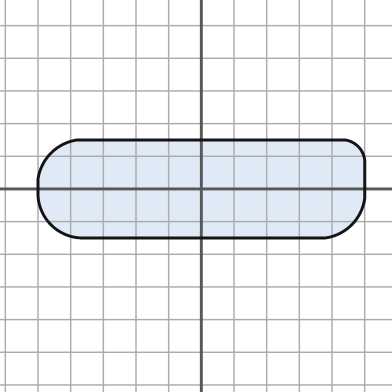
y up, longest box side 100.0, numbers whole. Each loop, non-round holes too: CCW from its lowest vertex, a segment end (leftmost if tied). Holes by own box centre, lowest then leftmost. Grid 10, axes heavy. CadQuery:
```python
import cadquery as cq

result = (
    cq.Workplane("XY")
    .moveTo(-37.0, -15.0)
    .lineTo(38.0, -15.0)
    .threePointArc((46.0, -11.0), (50.0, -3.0))
    .lineTo(50.0, 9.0)
    .threePointArc((48.0, 13.0), (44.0, 15.0))
    .lineTo(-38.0, 15.0)
    .threePointArc((-46.0, 11.0), (-50.0, 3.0))
    .lineTo(-50.0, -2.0)
    .threePointArc((-46.0, -11.0), (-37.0, -15.0))
    .close()
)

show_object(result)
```